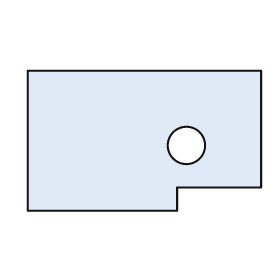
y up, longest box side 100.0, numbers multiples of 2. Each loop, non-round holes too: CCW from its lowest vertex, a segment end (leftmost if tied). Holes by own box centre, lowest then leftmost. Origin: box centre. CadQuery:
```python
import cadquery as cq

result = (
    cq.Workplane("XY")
    .moveTo(-50.0, -30.0)
    .lineTo(14.0, -30.0)
    .lineTo(14.0, -20.0)
    .lineTo(50.0, -20.0)
    .lineTo(50.0, 30.0)
    .lineTo(-50.0, 30.0)
    .close()
    .moveTo(18.0, -2.0)
    .circle(8.0)
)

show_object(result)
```